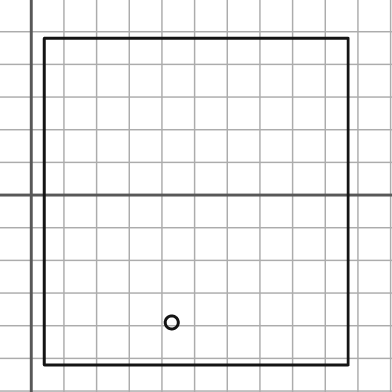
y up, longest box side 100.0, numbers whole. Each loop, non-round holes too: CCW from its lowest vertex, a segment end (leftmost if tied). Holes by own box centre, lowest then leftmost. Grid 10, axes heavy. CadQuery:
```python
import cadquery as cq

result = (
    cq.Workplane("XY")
    .moveTo(4.0, -52.0)
    .lineTo(97.0, -52.0)
    .lineTo(97.0, 48.0)
    .lineTo(4.0, 48.0)
    .close()
    .moveTo(43.0, -39.0)
    .circle(2.0)
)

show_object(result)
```